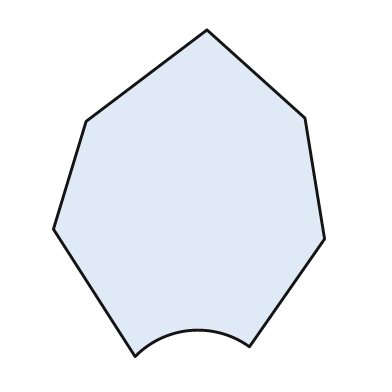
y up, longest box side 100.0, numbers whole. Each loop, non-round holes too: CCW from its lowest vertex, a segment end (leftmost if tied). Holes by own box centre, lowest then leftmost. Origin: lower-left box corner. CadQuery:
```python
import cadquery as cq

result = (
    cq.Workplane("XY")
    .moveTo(25.0, 0.0)
    .threePointArc((42.0, 8.0), (60.0, 3.0))
    .lineTo(83.0, 36.0)
    .lineTo(77.0, 73.0)
    .lineTo(47.0, 100.0)
    .lineTo(10.0, 72.0)
    .lineTo(0.0, 39.0)
    .close()
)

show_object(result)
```